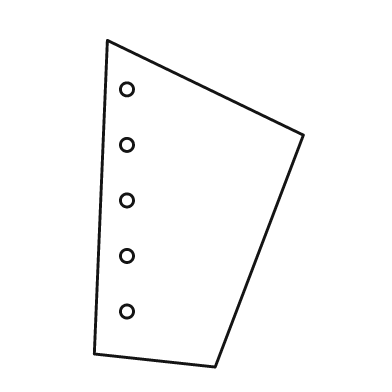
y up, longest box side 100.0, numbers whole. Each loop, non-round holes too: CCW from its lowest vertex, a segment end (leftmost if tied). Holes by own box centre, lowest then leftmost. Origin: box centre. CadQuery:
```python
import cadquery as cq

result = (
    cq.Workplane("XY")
    .moveTo(5.0, -50.0)
    .lineTo(32.0, 21.0)
    .lineTo(-28.0, 50.0)
    .lineTo(-32.0, -46.0)
    .close()
    .moveTo(-22.0, -33.0)
    .circle(2.0)
    .moveTo(-22.0, -16.0)
    .circle(2.0)
    .moveTo(-22.0, 1.0)
    .circle(2.0)
    .moveTo(-22.0, 18.0)
    .circle(2.0)
    .moveTo(-22.0, 35.0)
    .circle(2.0)
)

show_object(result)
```